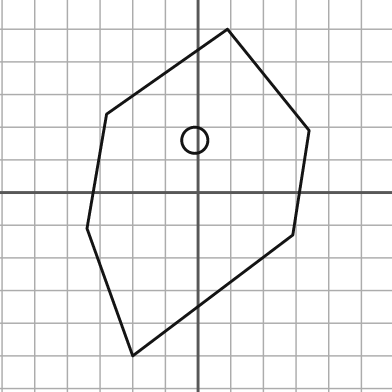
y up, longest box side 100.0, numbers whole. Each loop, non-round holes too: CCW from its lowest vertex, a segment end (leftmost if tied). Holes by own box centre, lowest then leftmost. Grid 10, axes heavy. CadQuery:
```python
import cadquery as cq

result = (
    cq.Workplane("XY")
    .moveTo(-20.0, -50.0)
    .lineTo(29.0, -13.0)
    .lineTo(34.0, 19.0)
    .lineTo(9.0, 50.0)
    .lineTo(-28.0, 24.0)
    .lineTo(-34.0, -11.0)
    .close()
    .moveTo(-1.0, 16.0)
    .circle(4.0)
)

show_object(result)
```